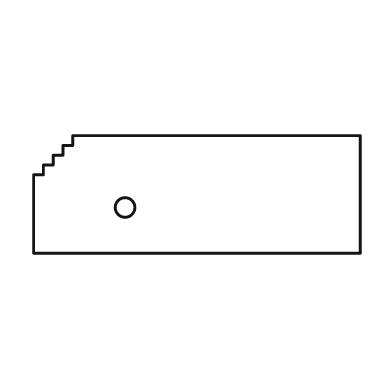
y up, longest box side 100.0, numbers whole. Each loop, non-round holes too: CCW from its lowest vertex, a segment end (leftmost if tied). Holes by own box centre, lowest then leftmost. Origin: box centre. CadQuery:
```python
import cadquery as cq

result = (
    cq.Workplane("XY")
    .moveTo(-50.0, -18.0)
    .lineTo(50.0, -18.0)
    .lineTo(50.0, 18.0)
    .lineTo(-38.0, 18.0)
    .lineTo(-38.0, 15.0)
    .lineTo(-41.0, 15.0)
    .lineTo(-41.0, 12.0)
    .lineTo(-44.0, 12.0)
    .lineTo(-44.0, 9.0)
    .lineTo(-47.0, 9.0)
    .lineTo(-47.0, 6.0)
    .lineTo(-50.0, 6.0)
    .close()
    .moveTo(-22.0, -4.0)
    .circle(3.0)
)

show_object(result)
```